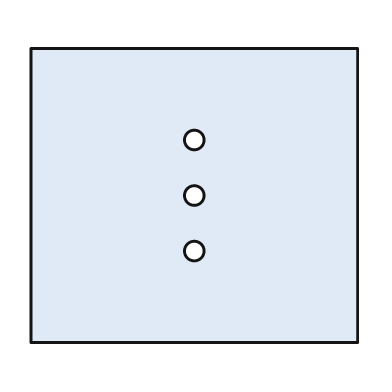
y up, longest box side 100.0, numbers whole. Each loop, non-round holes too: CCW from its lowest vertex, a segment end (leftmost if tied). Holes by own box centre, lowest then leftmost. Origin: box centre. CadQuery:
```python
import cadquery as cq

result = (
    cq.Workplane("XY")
    .moveTo(-50.0, -45.0)
    .lineTo(50.0, -45.0)
    .lineTo(50.0, 45.0)
    .lineTo(-50.0, 45.0)
    .close()
    .moveTo(0.0, -17.0)
    .circle(3.0)
    .moveTo(0.0, 0.0)
    .circle(3.0)
    .moveTo(0.0, 17.0)
    .circle(3.0)
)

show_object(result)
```